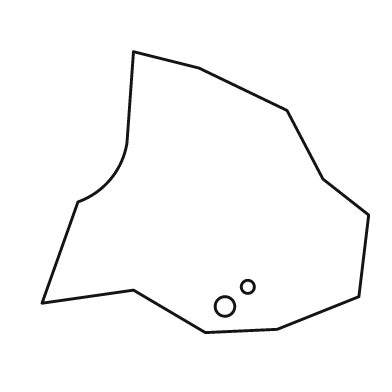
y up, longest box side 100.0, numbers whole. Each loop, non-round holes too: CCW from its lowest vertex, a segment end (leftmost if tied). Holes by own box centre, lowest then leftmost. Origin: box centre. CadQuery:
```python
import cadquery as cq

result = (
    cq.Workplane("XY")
    .moveTo(0.0, -43.0)
    .lineTo(22.0, -42.0)
    .lineTo(47.0, -32.0)
    .lineTo(50.0, -7.0)
    .lineTo(36.0, 4.0)
    .lineTo(25.0, 25.0)
    .lineTo(-2.0, 38.0)
    .lineTo(-22.0, 43.0)
    .lineTo(-24.0, 15.0)
    .threePointArc((-29.0, 4.0), (-39.0, -3.0))
    .lineTo(-50.0, -34.0)
    .lineTo(-22.0, -30.0)
    .close()
    .moveTo(6.0, -35.0)
    .circle(3.0)
    .moveTo(13.0, -29.0)
    .circle(2.0)
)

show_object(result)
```